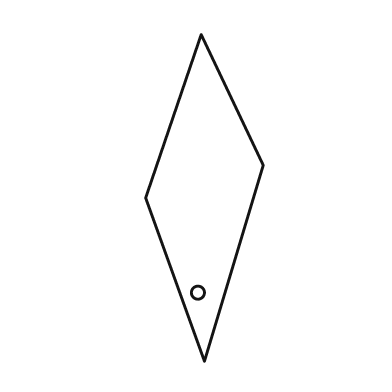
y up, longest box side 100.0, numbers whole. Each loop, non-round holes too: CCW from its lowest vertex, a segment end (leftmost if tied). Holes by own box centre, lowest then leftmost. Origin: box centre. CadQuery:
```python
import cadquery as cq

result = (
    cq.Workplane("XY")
    .moveTo(0.0, -50.0)
    .lineTo(18.0, 10.0)
    .lineTo(-1.0, 50.0)
    .lineTo(-18.0, 0.0)
    .close()
    .moveTo(-2.0, -29.0)
    .circle(2.0)
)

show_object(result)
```